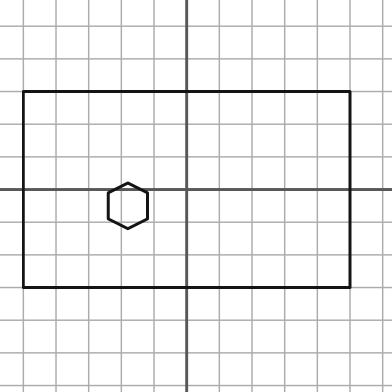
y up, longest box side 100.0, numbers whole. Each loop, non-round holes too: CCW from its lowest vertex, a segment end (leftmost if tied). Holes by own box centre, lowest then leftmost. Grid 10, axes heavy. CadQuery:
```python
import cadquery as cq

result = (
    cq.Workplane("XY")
    .moveTo(-50.0, -30.0)
    .lineTo(50.0, -30.0)
    .lineTo(50.0, 30.0)
    .lineTo(-50.0, 30.0)
    .close()
    .moveTo(-18.0, -12.0)
    .lineTo(-12.0, -9.0)
    .lineTo(-12.0, -1.0)
    .lineTo(-18.0, 2.0)
    .lineTo(-24.0, -1.0)
    .lineTo(-24.0, -9.0)
    .close()
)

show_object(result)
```